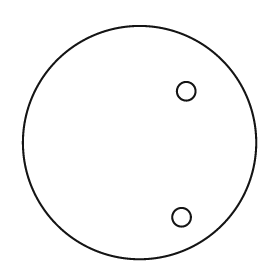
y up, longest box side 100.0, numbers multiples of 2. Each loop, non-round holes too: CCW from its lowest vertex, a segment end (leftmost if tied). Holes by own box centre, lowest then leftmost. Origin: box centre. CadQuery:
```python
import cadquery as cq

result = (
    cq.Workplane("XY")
    .moveTo(0.0, 0.0)
    .circle(50.0)
    .moveTo(18.0, -32.0)
    .circle(4.0)
    .moveTo(20.0, 22.0)
    .circle(4.0)
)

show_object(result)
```